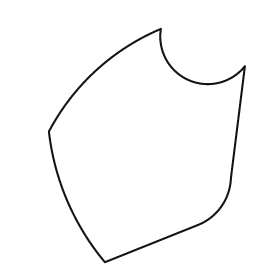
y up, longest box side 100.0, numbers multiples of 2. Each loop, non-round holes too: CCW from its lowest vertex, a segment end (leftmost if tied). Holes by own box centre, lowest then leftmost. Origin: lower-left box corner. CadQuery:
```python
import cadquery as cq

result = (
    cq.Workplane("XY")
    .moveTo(24.0, 0.0)
    .lineTo(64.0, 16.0)
    .threePointArc((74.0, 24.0), (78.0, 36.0))
    .lineTo(84.0, 84.0)
    .threePointArc((60.0, 78.0), (48.0, 100.0))
    .threePointArc((20.0, 82.0), (0.0, 56.0))
    .threePointArc((8.0, 26.0), (24.0, 0.0))
    .close()
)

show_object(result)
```